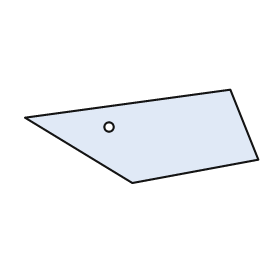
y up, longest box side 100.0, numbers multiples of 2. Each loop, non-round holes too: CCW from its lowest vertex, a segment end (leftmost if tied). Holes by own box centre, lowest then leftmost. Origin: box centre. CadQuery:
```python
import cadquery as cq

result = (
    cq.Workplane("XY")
    .moveTo(-4.0, -20.0)
    .lineTo(50.0, -10.0)
    .lineTo(38.0, 20.0)
    .lineTo(-50.0, 8.0)
    .close()
    .moveTo(-14.0, 4.0)
    .circle(2.0)
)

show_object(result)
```